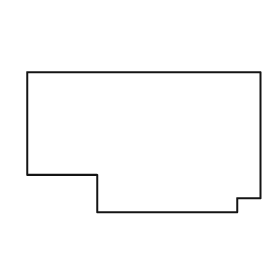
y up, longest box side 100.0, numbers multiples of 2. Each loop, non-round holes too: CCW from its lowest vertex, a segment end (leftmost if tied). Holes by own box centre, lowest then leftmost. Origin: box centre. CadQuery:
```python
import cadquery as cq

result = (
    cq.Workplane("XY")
    .moveTo(-20.0, -30.0)
    .lineTo(40.0, -30.0)
    .lineTo(40.0, -24.0)
    .lineTo(50.0, -24.0)
    .lineTo(50.0, 30.0)
    .lineTo(-50.0, 30.0)
    .lineTo(-50.0, -14.0)
    .lineTo(-20.0, -14.0)
    .close()
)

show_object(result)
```